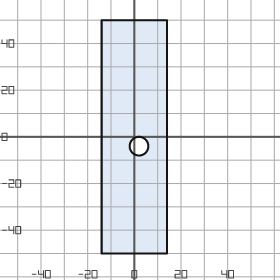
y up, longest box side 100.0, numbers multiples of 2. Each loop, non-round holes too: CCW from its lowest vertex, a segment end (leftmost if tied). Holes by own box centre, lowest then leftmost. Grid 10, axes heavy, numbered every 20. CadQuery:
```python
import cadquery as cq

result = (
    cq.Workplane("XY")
    .moveTo(-14.0, -50.0)
    .lineTo(14.0, -50.0)
    .lineTo(14.0, 50.0)
    .lineTo(-14.0, 50.0)
    .close()
    .moveTo(2.0, -4.0)
    .circle(4.0)
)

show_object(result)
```